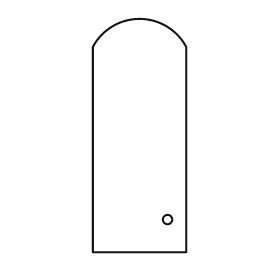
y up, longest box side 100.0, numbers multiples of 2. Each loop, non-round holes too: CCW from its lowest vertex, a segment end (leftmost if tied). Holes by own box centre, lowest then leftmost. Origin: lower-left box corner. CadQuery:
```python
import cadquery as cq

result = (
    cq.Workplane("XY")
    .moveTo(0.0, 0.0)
    .lineTo(40.0, 0.0)
    .lineTo(40.0, 88.0)
    .threePointArc((20.0, 100.0), (0.0, 88.0))
    .close()
    .moveTo(32.0, 14.0)
    .circle(2.0)
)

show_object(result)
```